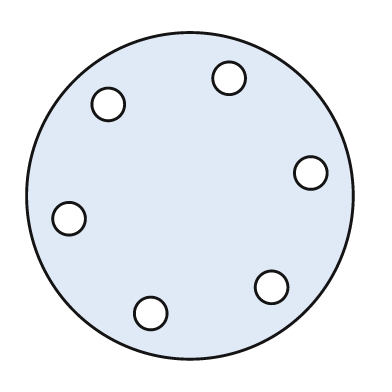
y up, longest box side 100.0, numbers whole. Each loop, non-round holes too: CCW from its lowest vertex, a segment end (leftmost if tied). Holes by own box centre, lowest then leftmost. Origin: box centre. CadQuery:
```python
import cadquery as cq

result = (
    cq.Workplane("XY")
    .moveTo(0.0, 0.0)
    .circle(50.0)
    .moveTo(-12.0, -36.0)
    .circle(5.0)
    .moveTo(25.0, -28.0)
    .circle(5.0)
    .moveTo(-37.0, -7.0)
    .circle(5.0)
    .moveTo(37.0, 7.0)
    .circle(5.0)
    .moveTo(-25.0, 28.0)
    .circle(5.0)
    .moveTo(12.0, 36.0)
    .circle(5.0)
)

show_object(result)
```